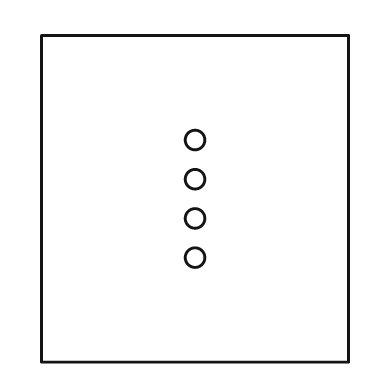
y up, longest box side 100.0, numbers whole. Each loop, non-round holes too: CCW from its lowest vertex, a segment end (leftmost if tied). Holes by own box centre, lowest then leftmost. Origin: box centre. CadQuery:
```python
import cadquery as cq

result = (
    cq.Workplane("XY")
    .moveTo(-47.0, -50.0)
    .lineTo(47.0, -50.0)
    .lineTo(47.0, 50.0)
    .lineTo(-47.0, 50.0)
    .close()
    .moveTo(0.0, -18.0)
    .circle(3.0)
    .moveTo(0.0, -6.0)
    .circle(3.0)
    .moveTo(0.0, 6.0)
    .circle(3.0)
    .moveTo(0.0, 18.0)
    .circle(3.0)
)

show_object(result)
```